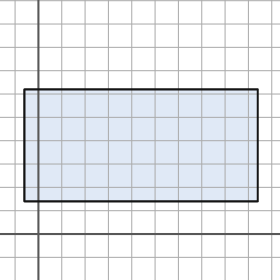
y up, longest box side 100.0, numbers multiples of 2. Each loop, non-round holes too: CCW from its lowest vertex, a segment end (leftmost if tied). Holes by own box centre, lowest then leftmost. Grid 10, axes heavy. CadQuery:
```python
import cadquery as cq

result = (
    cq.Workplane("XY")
    .moveTo(-6.0, 14.0)
    .lineTo(94.0, 14.0)
    .lineTo(94.0, 62.0)
    .lineTo(-6.0, 62.0)
    .close()
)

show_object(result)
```